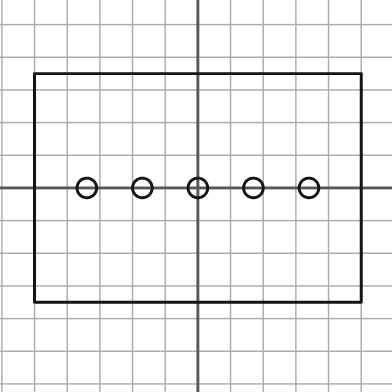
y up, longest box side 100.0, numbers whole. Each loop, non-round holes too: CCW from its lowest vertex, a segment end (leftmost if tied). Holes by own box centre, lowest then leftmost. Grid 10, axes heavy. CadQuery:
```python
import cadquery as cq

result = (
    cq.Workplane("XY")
    .moveTo(-50.0, -35.0)
    .lineTo(50.0, -35.0)
    .lineTo(50.0, 35.0)
    .lineTo(-50.0, 35.0)
    .close()
    .moveTo(-34.0, 0.0)
    .circle(3.0)
    .moveTo(-17.0, 0.0)
    .circle(3.0)
    .moveTo(0.0, 0.0)
    .circle(3.0)
    .moveTo(17.0, 0.0)
    .circle(3.0)
    .moveTo(34.0, 0.0)
    .circle(3.0)
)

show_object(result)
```